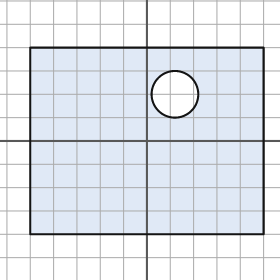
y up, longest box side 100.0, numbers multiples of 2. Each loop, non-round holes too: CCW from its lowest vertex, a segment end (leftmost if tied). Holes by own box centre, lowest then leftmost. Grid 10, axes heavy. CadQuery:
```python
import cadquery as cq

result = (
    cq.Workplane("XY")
    .moveTo(-50.0, -40.0)
    .lineTo(50.0, -40.0)
    .lineTo(50.0, 40.0)
    .lineTo(-50.0, 40.0)
    .close()
    .moveTo(12.0, 20.0)
    .circle(10.0)
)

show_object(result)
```